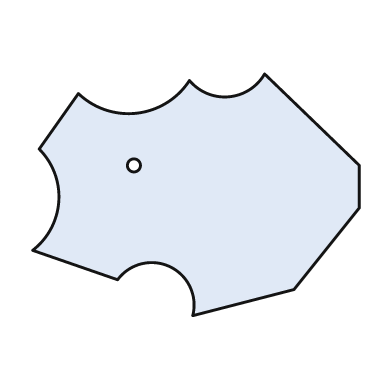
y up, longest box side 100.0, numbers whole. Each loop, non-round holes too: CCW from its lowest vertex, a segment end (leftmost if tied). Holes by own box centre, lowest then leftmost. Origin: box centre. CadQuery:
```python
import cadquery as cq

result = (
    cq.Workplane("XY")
    .moveTo(-1.0, -37.0)
    .lineTo(30.0, -29.0)
    .lineTo(50.0, -4.0)
    .lineTo(50.0, 9.0)
    .lineTo(21.0, 37.0)
    .threePointArc((10.0, 30.0), (-2.0, 35.0))
    .threePointArc((-18.0, 25.0), (-36.0, 31.0))
    .lineTo(-48.0, 14.0)
    .threePointArc((-42.0, -2.0), (-50.0, -17.0))
    .lineTo(-24.0, -26.0)
    .threePointArc((-8.0, -22.0), (-1.0, -37.0))
    .close()
    .moveTo(-19.0, 9.0)
    .circle(2.0)
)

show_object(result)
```